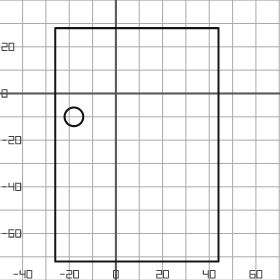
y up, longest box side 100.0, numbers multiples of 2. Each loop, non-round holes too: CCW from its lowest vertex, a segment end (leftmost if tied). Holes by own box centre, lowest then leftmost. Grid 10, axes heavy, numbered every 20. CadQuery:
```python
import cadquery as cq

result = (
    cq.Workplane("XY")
    .moveTo(-26.0, -72.0)
    .lineTo(44.0, -72.0)
    .lineTo(44.0, 28.0)
    .lineTo(-26.0, 28.0)
    .close()
    .moveTo(-18.0, -10.0)
    .circle(4.0)
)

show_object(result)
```